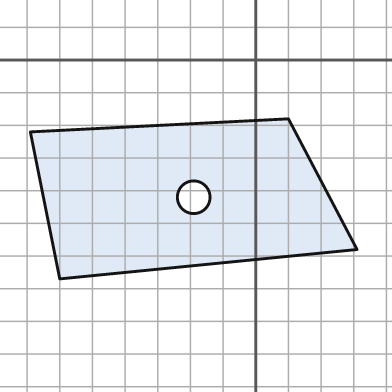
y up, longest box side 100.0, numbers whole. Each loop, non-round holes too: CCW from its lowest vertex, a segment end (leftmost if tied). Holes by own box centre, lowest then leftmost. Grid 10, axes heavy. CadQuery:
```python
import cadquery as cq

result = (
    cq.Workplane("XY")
    .moveTo(-60.0, -67.0)
    .lineTo(31.0, -58.0)
    .lineTo(10.0, -18.0)
    .lineTo(-69.0, -22.0)
    .close()
    .moveTo(-19.0, -42.0)
    .circle(5.0)
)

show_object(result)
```